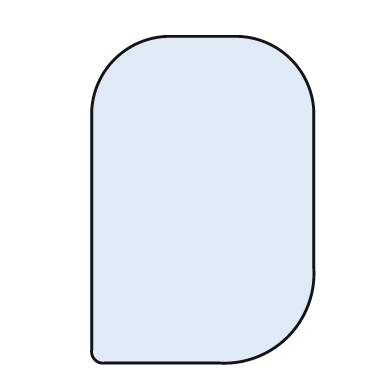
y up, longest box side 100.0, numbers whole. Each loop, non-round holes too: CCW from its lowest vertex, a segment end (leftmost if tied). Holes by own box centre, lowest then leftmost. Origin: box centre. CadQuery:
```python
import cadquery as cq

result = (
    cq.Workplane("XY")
    .moveTo(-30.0, -50.0)
    .lineTo(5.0, -50.0)
    .threePointArc((26.0, -42.0), (34.0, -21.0))
    .lineTo(34.0, 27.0)
    .threePointArc((27.0, 43.0), (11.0, 50.0))
    .lineTo(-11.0, 50.0)
    .threePointArc((-27.0, 43.0), (-34.0, 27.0))
    .lineTo(-34.0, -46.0)
    .threePointArc((-33.0, -49.0), (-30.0, -50.0))
    .close()
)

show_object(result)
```